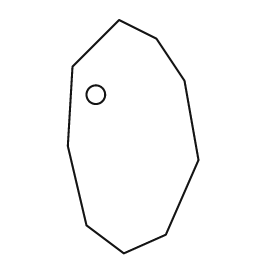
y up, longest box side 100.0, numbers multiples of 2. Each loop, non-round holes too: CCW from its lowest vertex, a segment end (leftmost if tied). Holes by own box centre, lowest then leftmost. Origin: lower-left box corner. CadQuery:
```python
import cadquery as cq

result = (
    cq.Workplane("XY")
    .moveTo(24.0, 0.0)
    .lineTo(42.0, 8.0)
    .lineTo(56.0, 40.0)
    .lineTo(50.0, 74.0)
    .lineTo(38.0, 92.0)
    .lineTo(22.0, 100.0)
    .lineTo(2.0, 80.0)
    .lineTo(0.0, 46.0)
    .lineTo(8.0, 12.0)
    .close()
    .moveTo(12.0, 68.0)
    .circle(4.0)
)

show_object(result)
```